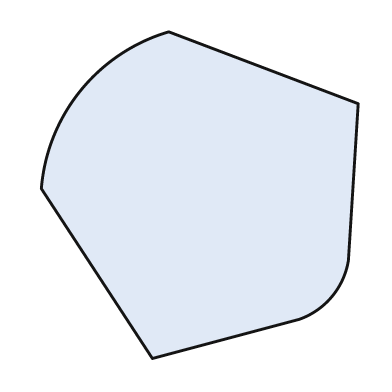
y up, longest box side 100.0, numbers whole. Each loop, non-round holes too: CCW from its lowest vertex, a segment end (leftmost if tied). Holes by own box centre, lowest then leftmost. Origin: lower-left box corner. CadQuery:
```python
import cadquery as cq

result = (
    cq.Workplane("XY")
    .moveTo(34.0, 0.0)
    .lineTo(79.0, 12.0)
    .threePointArc((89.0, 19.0), (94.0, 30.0))
    .lineTo(97.0, 78.0)
    .lineTo(39.0, 100.0)
    .threePointArc((12.0, 82.0), (0.0, 52.0))
    .close()
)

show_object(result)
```